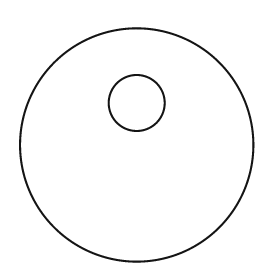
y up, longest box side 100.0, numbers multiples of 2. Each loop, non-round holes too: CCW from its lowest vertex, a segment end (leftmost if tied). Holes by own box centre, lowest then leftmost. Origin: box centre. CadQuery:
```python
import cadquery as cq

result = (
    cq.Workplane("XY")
    .moveTo(0.0, 0.0)
    .circle(50.0)
    .moveTo(0.0, 18.0)
    .circle(12.0)
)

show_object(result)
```